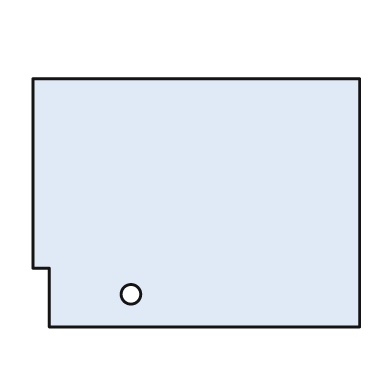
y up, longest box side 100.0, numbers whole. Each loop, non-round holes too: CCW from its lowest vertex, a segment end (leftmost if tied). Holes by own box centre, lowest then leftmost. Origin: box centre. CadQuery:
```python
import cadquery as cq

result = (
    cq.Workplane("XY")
    .moveTo(-45.0, -38.0)
    .lineTo(50.0, -38.0)
    .lineTo(50.0, 38.0)
    .lineTo(-50.0, 38.0)
    .lineTo(-50.0, -20.0)
    .lineTo(-45.0, -20.0)
    .close()
    .moveTo(-20.0, -28.0)
    .circle(3.0)
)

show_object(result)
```